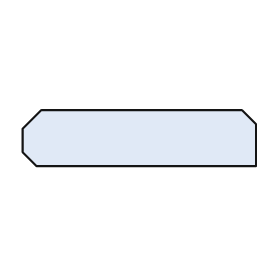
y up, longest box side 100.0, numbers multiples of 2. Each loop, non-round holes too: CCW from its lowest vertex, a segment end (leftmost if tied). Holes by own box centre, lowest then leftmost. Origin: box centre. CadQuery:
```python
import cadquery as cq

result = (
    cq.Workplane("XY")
    .moveTo(-44.0, -12.0)
    .lineTo(50.0, -12.0)
    .lineTo(50.0, 6.0)
    .lineTo(44.0, 12.0)
    .lineTo(-42.0, 12.0)
    .lineTo(-50.0, 4.0)
    .lineTo(-50.0, -6.0)
    .close()
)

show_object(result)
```